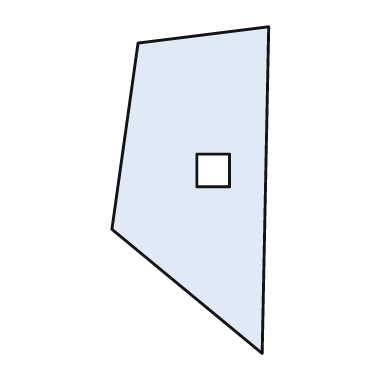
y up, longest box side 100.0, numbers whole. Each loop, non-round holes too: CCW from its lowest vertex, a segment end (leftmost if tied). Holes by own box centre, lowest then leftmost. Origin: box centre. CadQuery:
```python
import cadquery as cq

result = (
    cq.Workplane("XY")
    .moveTo(22.0, -50.0)
    .lineTo(24.0, 50.0)
    .lineTo(-16.0, 45.0)
    .lineTo(-24.0, -12.0)
    .close()
    .moveTo(2.0, 1.0)
    .lineTo(12.0, 1.0)
    .lineTo(12.0, 11.0)
    .lineTo(2.0, 11.0)
    .close()
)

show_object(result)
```